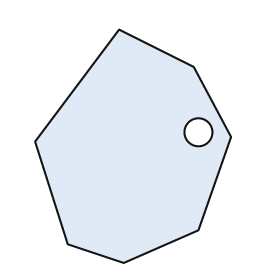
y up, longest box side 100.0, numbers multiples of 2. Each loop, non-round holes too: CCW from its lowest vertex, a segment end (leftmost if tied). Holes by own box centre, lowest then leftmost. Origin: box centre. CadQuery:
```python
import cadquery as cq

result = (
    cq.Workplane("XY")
    .moveTo(-4.0, -50.0)
    .lineTo(28.0, -36.0)
    .lineTo(42.0, 4.0)
    .lineTo(26.0, 34.0)
    .lineTo(-6.0, 50.0)
    .lineTo(-42.0, 2.0)
    .lineTo(-28.0, -42.0)
    .close()
    .moveTo(28.0, 6.0)
    .circle(6.0)
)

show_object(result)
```